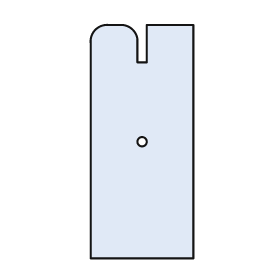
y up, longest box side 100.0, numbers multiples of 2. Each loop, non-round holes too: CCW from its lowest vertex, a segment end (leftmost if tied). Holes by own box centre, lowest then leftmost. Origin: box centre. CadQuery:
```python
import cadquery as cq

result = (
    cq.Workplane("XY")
    .moveTo(-22.0, -50.0)
    .lineTo(22.0, -50.0)
    .lineTo(22.0, 50.0)
    .lineTo(2.0, 50.0)
    .lineTo(2.0, 34.0)
    .lineTo(-2.0, 34.0)
    .lineTo(-2.0, 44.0)
    .threePointArc((-4.0, 48.0), (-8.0, 50.0))
    .lineTo(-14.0, 50.0)
    .threePointArc((-20.0, 48.0), (-22.0, 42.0))
    .close()
    .moveTo(0.0, 0.0)
    .circle(2.0)
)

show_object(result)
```